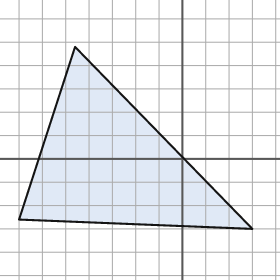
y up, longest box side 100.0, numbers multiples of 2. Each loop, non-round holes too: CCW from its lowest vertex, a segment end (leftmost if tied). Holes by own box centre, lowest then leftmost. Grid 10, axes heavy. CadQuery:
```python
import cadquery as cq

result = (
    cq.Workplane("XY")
    .moveTo(30.0, -30.0)
    .lineTo(-46.0, 48.0)
    .lineTo(-70.0, -26.0)
    .close()
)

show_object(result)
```